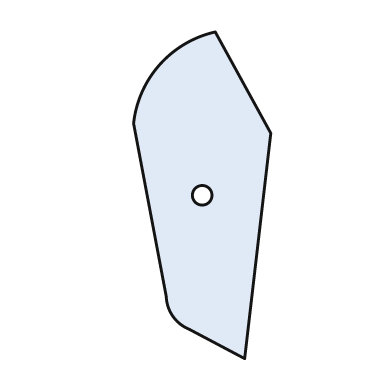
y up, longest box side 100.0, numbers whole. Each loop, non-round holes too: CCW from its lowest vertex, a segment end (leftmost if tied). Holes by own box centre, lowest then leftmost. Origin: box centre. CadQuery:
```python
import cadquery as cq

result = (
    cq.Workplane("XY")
    .moveTo(13.0, -50.0)
    .lineTo(21.0, 19.0)
    .lineTo(4.0, 50.0)
    .threePointArc((-13.0, 40.0), (-21.0, 22.0))
    .lineTo(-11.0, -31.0)
    .threePointArc((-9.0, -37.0), (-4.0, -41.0))
    .close()
    .moveTo(0.0, 0.0)
    .circle(3.0)
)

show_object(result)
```